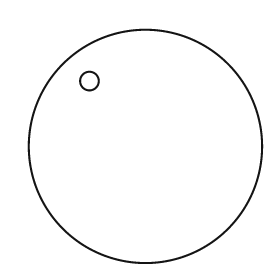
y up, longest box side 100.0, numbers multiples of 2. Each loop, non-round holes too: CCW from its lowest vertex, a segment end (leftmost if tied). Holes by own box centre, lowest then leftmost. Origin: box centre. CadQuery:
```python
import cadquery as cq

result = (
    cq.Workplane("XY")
    .moveTo(0.0, 0.0)
    .circle(50.0)
    .moveTo(-24.0, 28.0)
    .circle(4.0)
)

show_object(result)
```